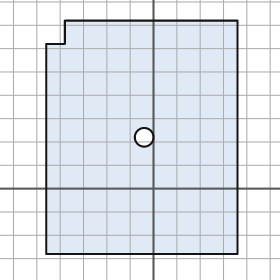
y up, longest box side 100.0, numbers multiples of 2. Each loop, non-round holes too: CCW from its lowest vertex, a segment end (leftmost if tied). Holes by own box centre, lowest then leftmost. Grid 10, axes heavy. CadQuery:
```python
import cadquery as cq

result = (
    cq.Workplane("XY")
    .moveTo(-46.0, -28.0)
    .lineTo(36.0, -28.0)
    .lineTo(36.0, 72.0)
    .lineTo(-38.0, 72.0)
    .lineTo(-38.0, 62.0)
    .lineTo(-46.0, 62.0)
    .close()
    .moveTo(-4.0, 22.0)
    .circle(4.0)
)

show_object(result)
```